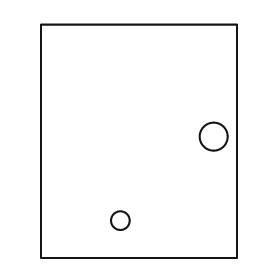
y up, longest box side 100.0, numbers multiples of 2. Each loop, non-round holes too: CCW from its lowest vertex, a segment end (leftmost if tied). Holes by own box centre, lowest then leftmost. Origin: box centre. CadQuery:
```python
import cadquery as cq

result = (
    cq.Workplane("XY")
    .moveTo(-42.0, -50.0)
    .lineTo(42.0, -50.0)
    .lineTo(42.0, 50.0)
    .lineTo(-42.0, 50.0)
    .close()
    .moveTo(-8.0, -34.0)
    .circle(4.0)
    .moveTo(32.0, 2.0)
    .circle(6.0)
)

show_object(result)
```